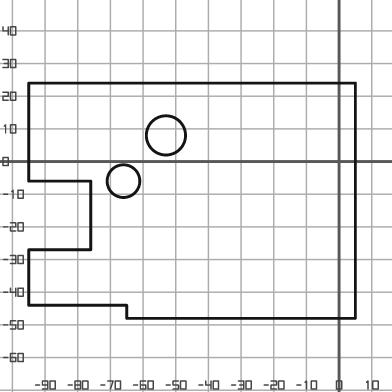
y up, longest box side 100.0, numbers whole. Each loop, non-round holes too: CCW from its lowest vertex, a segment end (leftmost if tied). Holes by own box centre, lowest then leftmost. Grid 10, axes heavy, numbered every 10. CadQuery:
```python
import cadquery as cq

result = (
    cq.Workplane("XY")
    .moveTo(-65.0, -48.0)
    .lineTo(5.0, -48.0)
    .lineTo(5.0, 24.0)
    .lineTo(-95.0, 24.0)
    .lineTo(-95.0, -6.0)
    .lineTo(-76.0, -6.0)
    .lineTo(-76.0, -27.0)
    .lineTo(-95.0, -27.0)
    .lineTo(-95.0, -44.0)
    .lineTo(-65.0, -44.0)
    .close()
    .moveTo(-66.0, -6.0)
    .circle(5.0)
    .moveTo(-53.0, 8.0)
    .circle(6.0)
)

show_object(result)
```